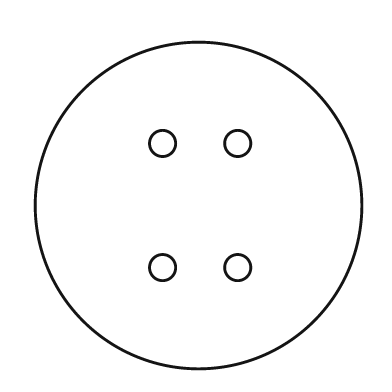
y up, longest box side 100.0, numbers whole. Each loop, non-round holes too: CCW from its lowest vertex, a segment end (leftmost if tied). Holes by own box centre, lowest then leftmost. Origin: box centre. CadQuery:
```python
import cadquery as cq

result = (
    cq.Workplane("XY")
    .moveTo(0.0, 0.0)
    .circle(50.0)
    .moveTo(-11.0, -19.0)
    .circle(4.0)
    .moveTo(12.0, -19.0)
    .circle(4.0)
    .moveTo(-11.0, 19.0)
    .circle(4.0)
    .moveTo(12.0, 19.0)
    .circle(4.0)
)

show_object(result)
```